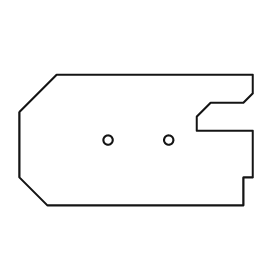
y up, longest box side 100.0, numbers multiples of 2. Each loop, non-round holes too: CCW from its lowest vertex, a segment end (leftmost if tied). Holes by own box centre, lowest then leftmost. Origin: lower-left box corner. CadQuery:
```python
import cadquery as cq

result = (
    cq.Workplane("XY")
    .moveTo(12.0, 0.0)
    .lineTo(96.0, 0.0)
    .lineTo(96.0, 12.0)
    .lineTo(100.0, 12.0)
    .lineTo(100.0, 32.0)
    .lineTo(76.0, 32.0)
    .lineTo(76.0, 38.0)
    .lineTo(82.0, 44.0)
    .lineTo(96.0, 44.0)
    .lineTo(100.0, 48.0)
    .lineTo(100.0, 56.0)
    .lineTo(16.0, 56.0)
    .lineTo(0.0, 40.0)
    .lineTo(0.0, 12.0)
    .close()
    .moveTo(38.0, 28.0)
    .circle(2.0)
    .moveTo(64.0, 28.0)
    .circle(2.0)
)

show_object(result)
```